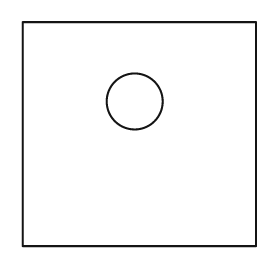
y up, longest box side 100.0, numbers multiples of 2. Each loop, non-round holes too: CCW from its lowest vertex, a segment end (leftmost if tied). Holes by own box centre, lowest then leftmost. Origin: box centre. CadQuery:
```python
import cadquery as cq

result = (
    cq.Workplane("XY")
    .moveTo(-50.0, -48.0)
    .lineTo(50.0, -48.0)
    .lineTo(50.0, 48.0)
    .lineTo(-50.0, 48.0)
    .close()
    .moveTo(-2.0, 14.0)
    .circle(12.0)
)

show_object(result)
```